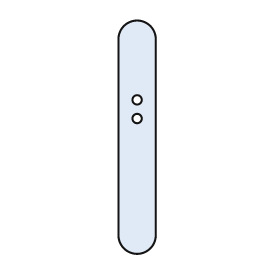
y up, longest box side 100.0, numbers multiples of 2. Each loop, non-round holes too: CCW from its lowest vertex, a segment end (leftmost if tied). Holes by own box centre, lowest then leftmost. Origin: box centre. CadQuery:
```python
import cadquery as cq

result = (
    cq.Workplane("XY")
    .moveTo(-8.0, -42.0)
    .threePointArc((0.0, -50.0), (8.0, -42.0))
    .lineTo(8.0, 42.0)
    .threePointArc((0.0, 50.0), (-8.0, 42.0))
    .close()
    .moveTo(0.0, 8.0)
    .circle(2.0)
    .moveTo(0.0, 16.0)
    .circle(2.0)
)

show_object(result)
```